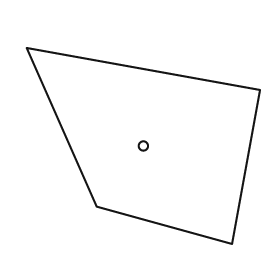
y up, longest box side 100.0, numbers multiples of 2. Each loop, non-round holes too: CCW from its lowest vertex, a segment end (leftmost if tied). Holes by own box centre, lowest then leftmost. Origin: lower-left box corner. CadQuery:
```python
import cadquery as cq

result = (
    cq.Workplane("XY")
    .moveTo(88.0, 0.0)
    .lineTo(100.0, 66.0)
    .lineTo(0.0, 84.0)
    .lineTo(30.0, 16.0)
    .close()
    .moveTo(50.0, 42.0)
    .circle(2.0)
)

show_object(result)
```